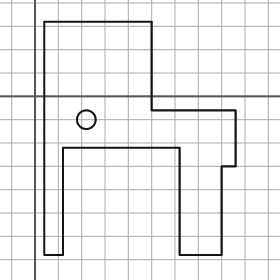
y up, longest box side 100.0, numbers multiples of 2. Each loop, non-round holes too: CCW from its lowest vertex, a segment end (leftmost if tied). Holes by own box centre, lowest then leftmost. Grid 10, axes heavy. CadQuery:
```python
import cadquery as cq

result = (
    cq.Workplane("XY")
    .moveTo(4.0, -68.0)
    .lineTo(12.0, -68.0)
    .lineTo(12.0, -22.0)
    .lineTo(62.0, -22.0)
    .lineTo(62.0, -68.0)
    .lineTo(80.0, -68.0)
    .lineTo(80.0, -30.0)
    .lineTo(86.0, -30.0)
    .lineTo(86.0, -6.0)
    .lineTo(50.0, -6.0)
    .lineTo(50.0, 32.0)
    .lineTo(4.0, 32.0)
    .close()
    .moveTo(22.0, -10.0)
    .circle(4.0)
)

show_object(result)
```